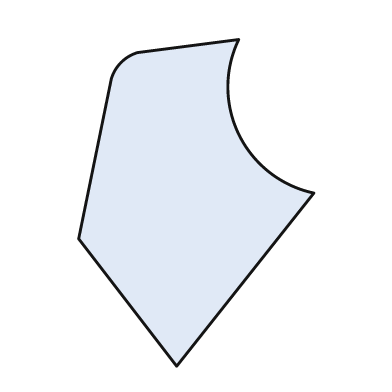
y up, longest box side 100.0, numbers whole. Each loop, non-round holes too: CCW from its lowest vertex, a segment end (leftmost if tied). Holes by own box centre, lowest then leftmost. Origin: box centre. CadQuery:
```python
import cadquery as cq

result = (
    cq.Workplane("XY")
    .moveTo(-6.0, -50.0)
    .lineTo(36.0, 3.0)
    .threePointArc((13.0, 21.0), (13.0, 50.0))
    .lineTo(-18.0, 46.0)
    .threePointArc((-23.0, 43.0), (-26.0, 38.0))
    .lineTo(-36.0, -11.0)
    .close()
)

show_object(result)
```